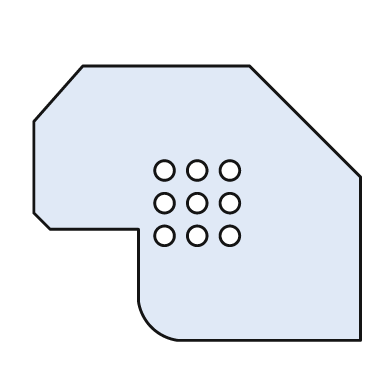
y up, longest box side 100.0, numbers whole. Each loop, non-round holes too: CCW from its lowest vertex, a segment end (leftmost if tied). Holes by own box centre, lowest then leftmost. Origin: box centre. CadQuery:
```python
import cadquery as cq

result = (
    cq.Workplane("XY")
    .moveTo(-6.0, -42.0)
    .lineTo(50.0, -42.0)
    .lineTo(50.0, 8.0)
    .lineTo(16.0, 42.0)
    .lineTo(-35.0, 42.0)
    .lineTo(-50.0, 25.0)
    .lineTo(-50.0, -3.0)
    .lineTo(-45.0, -8.0)
    .lineTo(-18.0, -8.0)
    .lineTo(-18.0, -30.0)
    .threePointArc((-14.0, -38.0), (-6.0, -42.0))
    .close()
    .moveTo(-10.0, -10.0)
    .circle(3.0)
    .moveTo(0.0, -10.0)
    .circle(3.0)
    .moveTo(10.0, -10.0)
    .circle(3.0)
    .moveTo(-10.0, 0.0)
    .circle(3.0)
    .moveTo(0.0, 0.0)
    .circle(3.0)
    .moveTo(10.0, 0.0)
    .circle(3.0)
    .moveTo(-10.0, 10.0)
    .circle(3.0)
    .moveTo(0.0, 10.0)
    .circle(3.0)
    .moveTo(10.0, 10.0)
    .circle(3.0)
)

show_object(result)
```